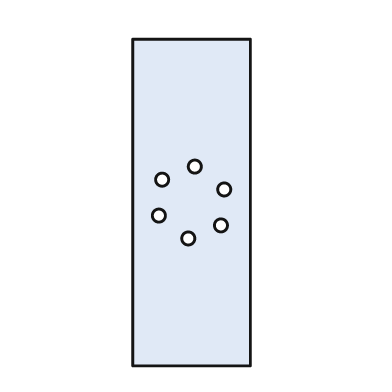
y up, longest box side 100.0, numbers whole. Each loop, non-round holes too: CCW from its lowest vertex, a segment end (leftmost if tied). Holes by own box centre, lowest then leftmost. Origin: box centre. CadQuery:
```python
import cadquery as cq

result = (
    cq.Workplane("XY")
    .moveTo(-18.0, -50.0)
    .lineTo(18.0, -50.0)
    .lineTo(18.0, 50.0)
    .lineTo(-18.0, 50.0)
    .close()
    .moveTo(-1.0, -11.0)
    .circle(2.0)
    .moveTo(9.0, -7.0)
    .circle(2.0)
    .moveTo(-10.0, -4.0)
    .circle(2.0)
    .moveTo(10.0, 4.0)
    .circle(2.0)
    .moveTo(-9.0, 7.0)
    .circle(2.0)
    .moveTo(1.0, 11.0)
    .circle(2.0)
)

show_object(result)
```